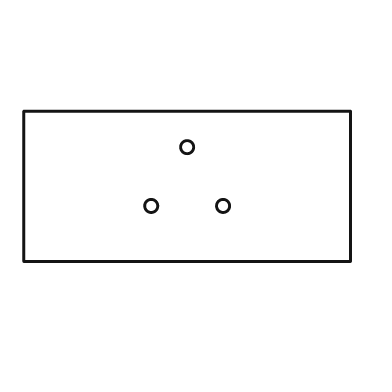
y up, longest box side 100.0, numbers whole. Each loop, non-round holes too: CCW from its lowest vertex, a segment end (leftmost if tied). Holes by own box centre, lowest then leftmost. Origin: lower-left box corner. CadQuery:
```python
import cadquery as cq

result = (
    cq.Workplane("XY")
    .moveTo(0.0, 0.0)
    .lineTo(100.0, 0.0)
    .lineTo(100.0, 46.0)
    .lineTo(0.0, 46.0)
    .close()
    .moveTo(39.0, 17.0)
    .circle(2.0)
    .moveTo(61.0, 17.0)
    .circle(2.0)
    .moveTo(50.0, 35.0)
    .circle(2.0)
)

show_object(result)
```